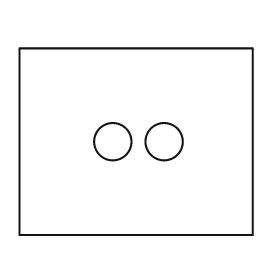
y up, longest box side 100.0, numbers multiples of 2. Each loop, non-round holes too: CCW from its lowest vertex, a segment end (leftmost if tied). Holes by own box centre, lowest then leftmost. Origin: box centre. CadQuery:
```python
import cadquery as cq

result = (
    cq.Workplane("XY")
    .moveTo(-50.0, -40.0)
    .lineTo(50.0, -40.0)
    .lineTo(50.0, 40.0)
    .lineTo(-50.0, 40.0)
    .close()
    .moveTo(-10.0, 0.0)
    .circle(8.0)
    .moveTo(12.0, 0.0)
    .circle(8.0)
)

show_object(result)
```